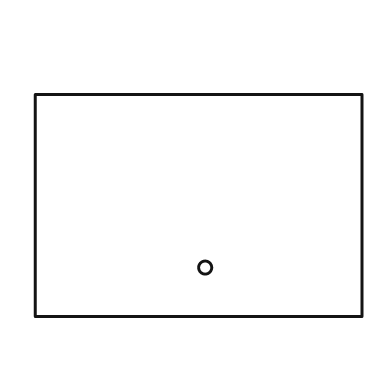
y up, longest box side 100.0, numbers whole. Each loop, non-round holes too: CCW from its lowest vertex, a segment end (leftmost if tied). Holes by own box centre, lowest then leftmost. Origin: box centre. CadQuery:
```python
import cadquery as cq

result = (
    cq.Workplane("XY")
    .moveTo(-50.0, -34.0)
    .lineTo(50.0, -34.0)
    .lineTo(50.0, 34.0)
    .lineTo(-50.0, 34.0)
    .close()
    .moveTo(2.0, -19.0)
    .circle(2.0)
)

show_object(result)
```